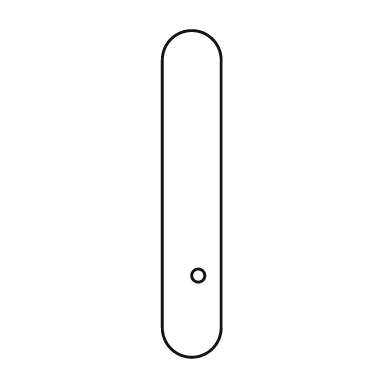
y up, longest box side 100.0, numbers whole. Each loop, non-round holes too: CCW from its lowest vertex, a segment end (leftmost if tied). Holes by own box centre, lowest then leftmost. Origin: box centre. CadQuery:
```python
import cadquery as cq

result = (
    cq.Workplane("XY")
    .moveTo(-9.0, -41.0)
    .threePointArc((0.0, -50.0), (9.0, -41.0))
    .lineTo(9.0, 41.0)
    .threePointArc((0.0, 50.0), (-9.0, 41.0))
    .close()
    .moveTo(2.0, -25.0)
    .circle(2.0)
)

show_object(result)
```